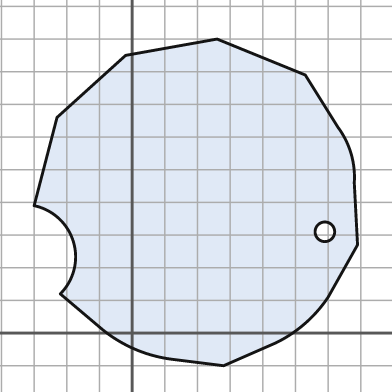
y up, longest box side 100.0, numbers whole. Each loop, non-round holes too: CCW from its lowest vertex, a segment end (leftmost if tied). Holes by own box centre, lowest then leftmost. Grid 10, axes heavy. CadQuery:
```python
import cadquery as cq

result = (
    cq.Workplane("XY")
    .moveTo(28.0, -10.0)
    .lineTo(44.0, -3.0)
    .threePointArc((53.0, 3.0), (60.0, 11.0))
    .lineTo(69.0, 27.0)
    .lineTo(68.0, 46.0)
    .threePointArc((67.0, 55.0), (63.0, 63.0))
    .lineTo(53.0, 79.0)
    .lineTo(26.0, 90.0)
    .lineTo(-2.0, 85.0)
    .lineTo(-23.0, 66.0)
    .lineTo(-30.0, 39.0)
    .threePointArc((-18.0, 28.0), (-22.0, 12.0))
    .lineTo(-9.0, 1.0)
    .threePointArc((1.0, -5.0), (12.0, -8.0))
    .close()
    .moveTo(59.0, 31.0)
    .circle(3.0)
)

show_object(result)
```